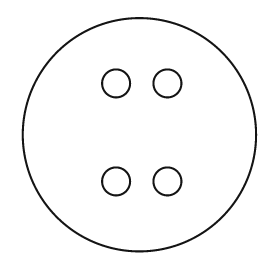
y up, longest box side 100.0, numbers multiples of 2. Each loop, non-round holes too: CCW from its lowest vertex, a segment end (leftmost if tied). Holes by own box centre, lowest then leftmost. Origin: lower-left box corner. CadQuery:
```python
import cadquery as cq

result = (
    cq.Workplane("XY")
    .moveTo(50.0, 50.0)
    .circle(50.0)
    .moveTo(40.0, 30.0)
    .circle(6.0)
    .moveTo(62.0, 30.0)
    .circle(6.0)
    .moveTo(40.0, 72.0)
    .circle(6.0)
    .moveTo(62.0, 72.0)
    .circle(6.0)
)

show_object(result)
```